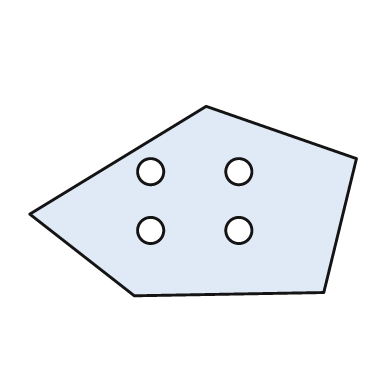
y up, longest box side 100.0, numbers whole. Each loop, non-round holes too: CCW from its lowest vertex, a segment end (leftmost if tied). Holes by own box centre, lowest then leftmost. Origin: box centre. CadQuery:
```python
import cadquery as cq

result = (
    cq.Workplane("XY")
    .moveTo(-18.0, -29.0)
    .lineTo(40.0, -28.0)
    .lineTo(50.0, 13.0)
    .lineTo(4.0, 29.0)
    .lineTo(-50.0, -4.0)
    .close()
    .moveTo(-13.0, -9.0)
    .circle(4.0)
    .moveTo(14.0, -9.0)
    .circle(4.0)
    .moveTo(-13.0, 9.0)
    .circle(4.0)
    .moveTo(14.0, 9.0)
    .circle(4.0)
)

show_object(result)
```